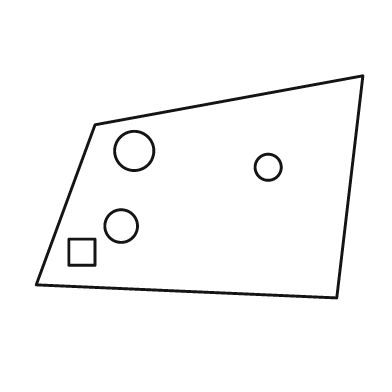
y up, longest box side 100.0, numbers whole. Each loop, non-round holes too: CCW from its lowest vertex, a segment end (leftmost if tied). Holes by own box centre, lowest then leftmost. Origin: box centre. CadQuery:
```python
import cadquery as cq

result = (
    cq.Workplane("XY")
    .moveTo(42.0, -34.0)
    .lineTo(50.0, 34.0)
    .lineTo(-32.0, 19.0)
    .lineTo(-50.0, -30.0)
    .close()
    .moveTo(-40.0, -24.0)
    .lineTo(-32.0, -24.0)
    .lineTo(-32.0, -16.0)
    .lineTo(-40.0, -16.0)
    .close()
    .moveTo(-24.0, -12.0)
    .circle(5.0)
    .moveTo(21.0, 6.0)
    .circle(4.0)
    .moveTo(-20.0, 11.0)
    .circle(6.0)
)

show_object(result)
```